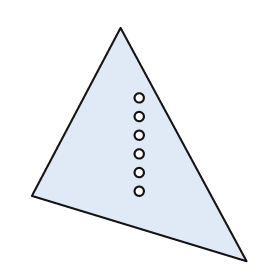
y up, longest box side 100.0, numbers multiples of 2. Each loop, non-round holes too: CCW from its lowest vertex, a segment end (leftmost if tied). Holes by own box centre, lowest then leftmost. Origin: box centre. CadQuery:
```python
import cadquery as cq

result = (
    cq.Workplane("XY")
    .moveTo(46.0, -50.0)
    .lineTo(-8.0, 50.0)
    .lineTo(-46.0, -22.0)
    .close()
    .moveTo(0.0, -20.0)
    .circle(2.0)
    .moveTo(0.0, -12.0)
    .circle(2.0)
    .moveTo(0.0, -4.0)
    .circle(2.0)
    .moveTo(0.0, 4.0)
    .circle(2.0)
    .moveTo(0.0, 12.0)
    .circle(2.0)
    .moveTo(0.0, 20.0)
    .circle(2.0)
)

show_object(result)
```